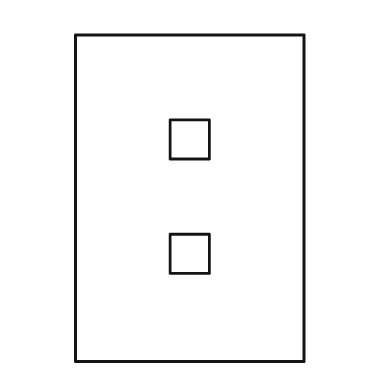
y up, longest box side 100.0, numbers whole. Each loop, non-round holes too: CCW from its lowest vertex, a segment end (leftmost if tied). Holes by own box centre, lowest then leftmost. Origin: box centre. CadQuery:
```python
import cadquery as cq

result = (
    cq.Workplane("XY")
    .moveTo(-35.0, -50.0)
    .lineTo(35.0, -50.0)
    .lineTo(35.0, 50.0)
    .lineTo(-35.0, 50.0)
    .close()
    .moveTo(-6.0, -23.0)
    .lineTo(6.0, -23.0)
    .lineTo(6.0, -11.0)
    .lineTo(-6.0, -11.0)
    .close()
    .moveTo(-6.0, 12.0)
    .lineTo(6.0, 12.0)
    .lineTo(6.0, 24.0)
    .lineTo(-6.0, 24.0)
    .close()
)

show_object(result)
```